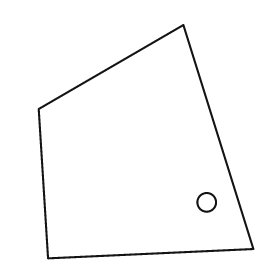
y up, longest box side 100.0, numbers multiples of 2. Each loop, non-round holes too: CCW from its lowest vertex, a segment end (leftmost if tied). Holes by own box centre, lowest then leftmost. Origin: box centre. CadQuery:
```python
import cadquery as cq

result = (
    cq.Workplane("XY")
    .moveTo(-42.0, -50.0)
    .lineTo(46.0, -46.0)
    .lineTo(16.0, 50.0)
    .lineTo(-46.0, 14.0)
    .close()
    .moveTo(26.0, -26.0)
    .circle(4.0)
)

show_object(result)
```